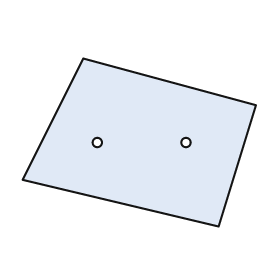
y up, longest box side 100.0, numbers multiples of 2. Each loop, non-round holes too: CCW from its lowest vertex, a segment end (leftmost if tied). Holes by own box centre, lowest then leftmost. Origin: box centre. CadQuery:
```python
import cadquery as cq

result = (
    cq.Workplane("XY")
    .moveTo(34.0, -36.0)
    .lineTo(50.0, 16.0)
    .lineTo(-24.0, 36.0)
    .lineTo(-50.0, -16.0)
    .close()
    .moveTo(-18.0, 0.0)
    .circle(2.0)
    .moveTo(20.0, 0.0)
    .circle(2.0)
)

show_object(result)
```